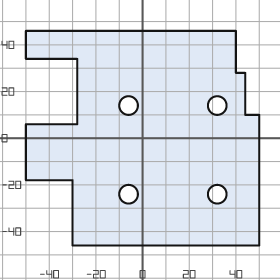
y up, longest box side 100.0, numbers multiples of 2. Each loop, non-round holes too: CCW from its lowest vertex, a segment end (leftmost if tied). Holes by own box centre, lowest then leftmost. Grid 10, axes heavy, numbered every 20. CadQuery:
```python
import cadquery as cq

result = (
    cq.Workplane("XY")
    .moveTo(-30.0, -46.0)
    .lineTo(50.0, -46.0)
    .lineTo(50.0, 10.0)
    .lineTo(44.0, 10.0)
    .lineTo(44.0, 28.0)
    .lineTo(40.0, 28.0)
    .lineTo(40.0, 46.0)
    .lineTo(-50.0, 46.0)
    .lineTo(-50.0, 34.0)
    .lineTo(-28.0, 34.0)
    .lineTo(-28.0, 6.0)
    .lineTo(-50.0, 6.0)
    .lineTo(-50.0, -18.0)
    .lineTo(-30.0, -18.0)
    .close()
    .moveTo(-6.0, -24.0)
    .circle(4.0)
    .moveTo(32.0, -24.0)
    .circle(4.0)
    .moveTo(-6.0, 14.0)
    .circle(4.0)
    .moveTo(32.0, 14.0)
    .circle(4.0)
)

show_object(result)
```